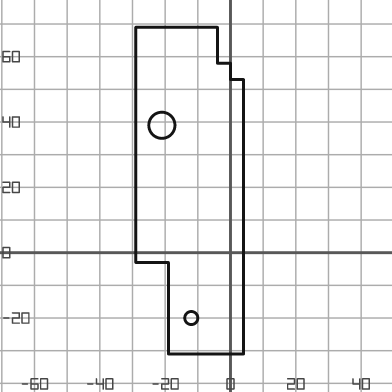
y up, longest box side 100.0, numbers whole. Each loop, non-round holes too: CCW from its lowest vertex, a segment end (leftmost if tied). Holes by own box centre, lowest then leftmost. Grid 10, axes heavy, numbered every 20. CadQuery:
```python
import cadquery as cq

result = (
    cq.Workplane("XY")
    .moveTo(-19.0, -31.0)
    .lineTo(4.0, -31.0)
    .lineTo(4.0, 53.0)
    .lineTo(0.0, 53.0)
    .lineTo(0.0, 58.0)
    .lineTo(-4.0, 58.0)
    .lineTo(-4.0, 69.0)
    .lineTo(-29.0, 69.0)
    .lineTo(-29.0, -3.0)
    .lineTo(-19.0, -3.0)
    .close()
    .moveTo(-12.0, -20.0)
    .circle(2.0)
    .moveTo(-21.0, 39.0)
    .circle(4.0)
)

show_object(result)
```